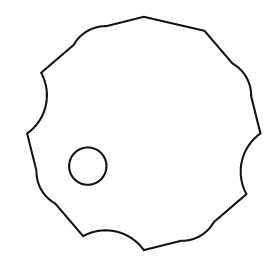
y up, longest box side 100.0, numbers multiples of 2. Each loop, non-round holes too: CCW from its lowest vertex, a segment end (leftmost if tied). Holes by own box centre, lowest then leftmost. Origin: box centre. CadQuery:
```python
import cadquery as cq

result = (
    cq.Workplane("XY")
    .moveTo(0.0, -50.0)
    .lineTo(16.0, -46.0)
    .threePointArc((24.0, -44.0), (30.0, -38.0))
    .lineTo(44.0, -26.0)
    .threePointArc((42.0, -12.0), (50.0, 0.0))
    .lineTo(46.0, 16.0)
    .threePointArc((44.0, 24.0), (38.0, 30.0))
    .lineTo(26.0, 44.0)
    .lineTo(0.0, 50.0)
    .lineTo(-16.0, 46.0)
    .threePointArc((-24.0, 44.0), (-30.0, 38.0))
    .lineTo(-44.0, 26.0)
    .threePointArc((-42.0, 12.0), (-50.0, 0.0))
    .lineTo(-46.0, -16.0)
    .threePointArc((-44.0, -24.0), (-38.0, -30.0))
    .lineTo(-26.0, -44.0)
    .threePointArc((-12.0, -42.0), (0.0, -50.0))
    .close()
    .moveTo(-24.0, -14.0)
    .circle(8.0)
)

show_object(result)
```